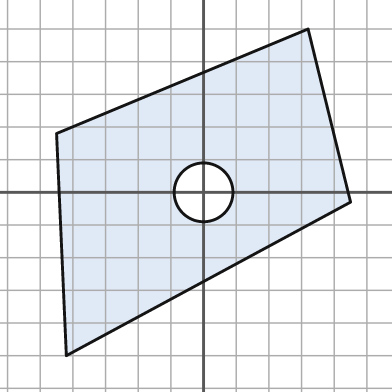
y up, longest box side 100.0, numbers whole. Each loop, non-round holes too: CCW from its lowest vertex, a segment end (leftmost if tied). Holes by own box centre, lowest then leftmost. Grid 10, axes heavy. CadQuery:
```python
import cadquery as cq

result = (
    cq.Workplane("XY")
    .moveTo(-42.0, -50.0)
    .lineTo(45.0, -3.0)
    .lineTo(32.0, 50.0)
    .lineTo(-45.0, 18.0)
    .close()
    .moveTo(0.0, 0.0)
    .circle(9.0)
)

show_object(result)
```